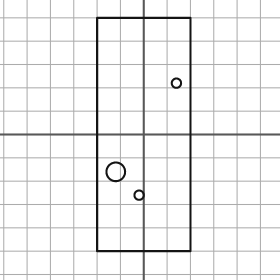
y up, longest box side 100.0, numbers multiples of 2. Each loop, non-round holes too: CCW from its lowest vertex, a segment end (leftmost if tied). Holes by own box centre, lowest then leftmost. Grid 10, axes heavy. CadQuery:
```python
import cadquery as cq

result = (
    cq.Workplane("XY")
    .moveTo(-20.0, -50.0)
    .lineTo(20.0, -50.0)
    .lineTo(20.0, 50.0)
    .lineTo(-20.0, 50.0)
    .close()
    .moveTo(-2.0, -26.0)
    .circle(2.0)
    .moveTo(-12.0, -16.0)
    .circle(4.0)
    .moveTo(14.0, 22.0)
    .circle(2.0)
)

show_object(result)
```